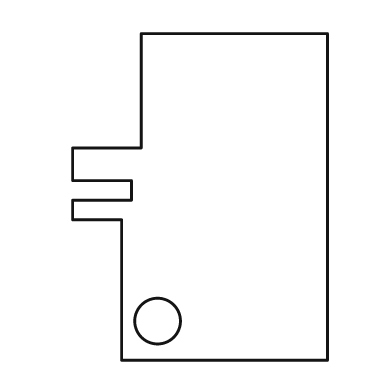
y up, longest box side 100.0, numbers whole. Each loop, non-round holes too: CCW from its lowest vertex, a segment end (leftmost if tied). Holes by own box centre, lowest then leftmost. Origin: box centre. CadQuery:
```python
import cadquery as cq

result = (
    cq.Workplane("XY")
    .moveTo(-24.0, -50.0)
    .lineTo(39.0, -50.0)
    .lineTo(39.0, 50.0)
    .lineTo(-18.0, 50.0)
    .lineTo(-18.0, 15.0)
    .lineTo(-39.0, 15.0)
    .lineTo(-39.0, 5.0)
    .lineTo(-21.0, 5.0)
    .lineTo(-21.0, -1.0)
    .lineTo(-39.0, -1.0)
    .lineTo(-39.0, -7.0)
    .lineTo(-24.0, -7.0)
    .close()
    .moveTo(-13.0, -38.0)
    .circle(7.0)
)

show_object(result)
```